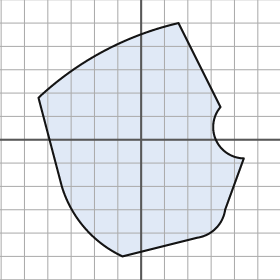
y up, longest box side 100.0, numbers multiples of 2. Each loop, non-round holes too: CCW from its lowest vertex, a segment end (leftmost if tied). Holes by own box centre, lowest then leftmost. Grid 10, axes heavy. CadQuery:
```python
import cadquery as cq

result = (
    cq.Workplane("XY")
    .moveTo(-8.0, -50.0)
    .lineTo(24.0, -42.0)
    .threePointArc((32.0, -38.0), (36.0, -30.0))
    .lineTo(44.0, -8.0)
    .threePointArc((32.0, 0.0), (34.0, 14.0))
    .lineTo(16.0, 50.0)
    .threePointArc((-16.0, 38.0), (-44.0, 18.0))
    .lineTo(-34.0, -20.0)
    .threePointArc((-24.0, -38.0), (-8.0, -50.0))
    .close()
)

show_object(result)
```